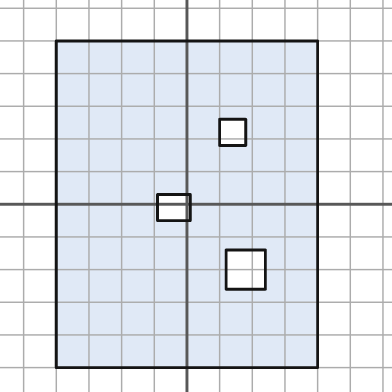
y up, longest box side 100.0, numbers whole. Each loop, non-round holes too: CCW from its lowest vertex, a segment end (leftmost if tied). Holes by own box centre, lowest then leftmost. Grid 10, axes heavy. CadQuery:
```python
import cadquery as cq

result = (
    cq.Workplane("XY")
    .moveTo(-40.0, -50.0)
    .lineTo(40.0, -50.0)
    .lineTo(40.0, 50.0)
    .lineTo(-40.0, 50.0)
    .close()
    .moveTo(12.0, -26.0)
    .lineTo(24.0, -26.0)
    .lineTo(24.0, -14.0)
    .lineTo(12.0, -14.0)
    .close()
    .moveTo(-9.0, -5.0)
    .lineTo(1.0, -5.0)
    .lineTo(1.0, 3.0)
    .lineTo(-9.0, 3.0)
    .close()
    .moveTo(10.0, 18.0)
    .lineTo(18.0, 18.0)
    .lineTo(18.0, 26.0)
    .lineTo(10.0, 26.0)
    .close()
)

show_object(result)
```